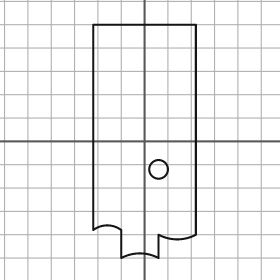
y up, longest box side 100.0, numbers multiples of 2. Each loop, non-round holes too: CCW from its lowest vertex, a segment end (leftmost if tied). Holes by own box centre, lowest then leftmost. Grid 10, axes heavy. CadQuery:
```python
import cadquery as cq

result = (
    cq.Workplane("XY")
    .moveTo(-10.0, -50.0)
    .threePointArc((-2.0, -48.0), (6.0, -50.0))
    .lineTo(6.0, -40.0)
    .threePointArc((14.0, -42.0), (22.0, -40.0))
    .lineTo(22.0, 50.0)
    .lineTo(-22.0, 50.0)
    .lineTo(-22.0, -38.0)
    .threePointArc((-16.0, -36.0), (-10.0, -38.0))
    .close()
    .moveTo(6.0, -12.0)
    .circle(4.0)
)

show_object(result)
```